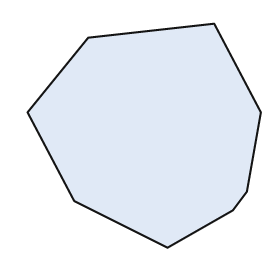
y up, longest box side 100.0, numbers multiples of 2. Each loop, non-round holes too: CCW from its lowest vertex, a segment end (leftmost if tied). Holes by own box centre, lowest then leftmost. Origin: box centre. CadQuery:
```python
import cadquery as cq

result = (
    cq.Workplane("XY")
    .moveTo(10.0, -48.0)
    .lineTo(38.0, -32.0)
    .lineTo(44.0, -24.0)
    .lineTo(50.0, 10.0)
    .lineTo(30.0, 48.0)
    .lineTo(-24.0, 42.0)
    .lineTo(-50.0, 10.0)
    .lineTo(-30.0, -28.0)
    .close()
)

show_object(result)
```